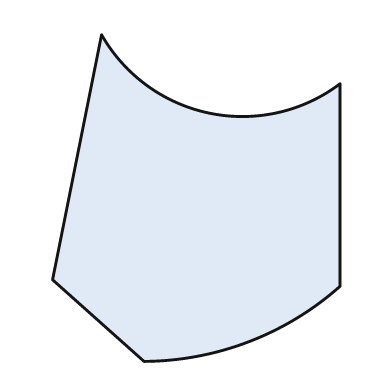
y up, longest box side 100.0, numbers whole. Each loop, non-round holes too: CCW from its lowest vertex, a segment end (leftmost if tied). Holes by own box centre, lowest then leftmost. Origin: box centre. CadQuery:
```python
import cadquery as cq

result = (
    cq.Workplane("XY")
    .moveTo(-16.0, -50.0)
    .threePointArc((16.0, -44.0), (44.0, -27.0))
    .lineTo(44.0, 35.0)
    .threePointArc((4.0, 26.0), (-29.0, 50.0))
    .lineTo(-44.0, -25.0)
    .close()
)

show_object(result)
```